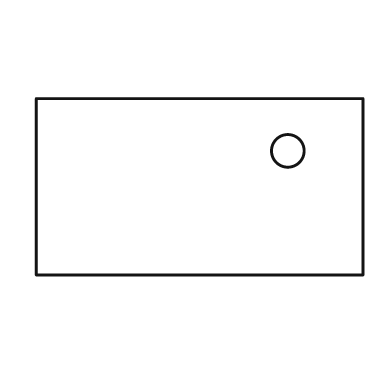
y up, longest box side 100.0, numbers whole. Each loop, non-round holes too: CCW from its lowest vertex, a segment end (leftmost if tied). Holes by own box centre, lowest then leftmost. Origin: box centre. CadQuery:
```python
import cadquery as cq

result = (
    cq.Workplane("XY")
    .moveTo(-50.0, -27.0)
    .lineTo(50.0, -27.0)
    .lineTo(50.0, 27.0)
    .lineTo(-50.0, 27.0)
    .close()
    .moveTo(27.0, 11.0)
    .circle(5.0)
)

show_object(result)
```